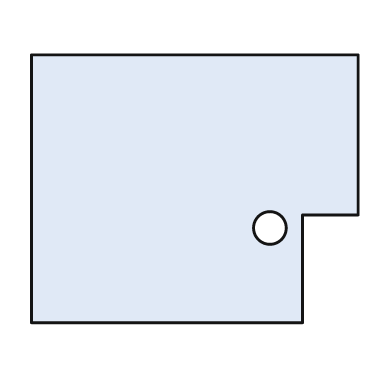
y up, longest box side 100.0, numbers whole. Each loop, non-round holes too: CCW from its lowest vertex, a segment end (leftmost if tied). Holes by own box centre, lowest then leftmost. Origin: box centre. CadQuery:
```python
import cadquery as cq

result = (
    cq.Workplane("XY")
    .moveTo(-50.0, -41.0)
    .lineTo(33.0, -41.0)
    .lineTo(33.0, -8.0)
    .lineTo(50.0, -8.0)
    .lineTo(50.0, 41.0)
    .lineTo(-50.0, 41.0)
    .close()
    .moveTo(23.0, -12.0)
    .circle(5.0)
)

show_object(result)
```